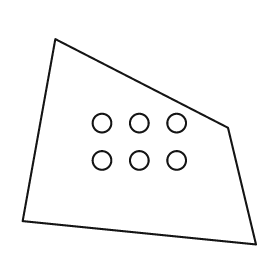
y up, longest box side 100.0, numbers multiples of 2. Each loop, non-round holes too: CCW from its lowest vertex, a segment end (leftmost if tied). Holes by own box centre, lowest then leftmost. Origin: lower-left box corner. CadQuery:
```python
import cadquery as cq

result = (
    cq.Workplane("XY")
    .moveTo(100.0, 0.0)
    .lineTo(88.0, 50.0)
    .lineTo(14.0, 88.0)
    .lineTo(0.0, 10.0)
    .close()
    .moveTo(34.0, 36.0)
    .circle(4.0)
    .moveTo(50.0, 36.0)
    .circle(4.0)
    .moveTo(66.0, 36.0)
    .circle(4.0)
    .moveTo(34.0, 52.0)
    .circle(4.0)
    .moveTo(50.0, 52.0)
    .circle(4.0)
    .moveTo(66.0, 52.0)
    .circle(4.0)
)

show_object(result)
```